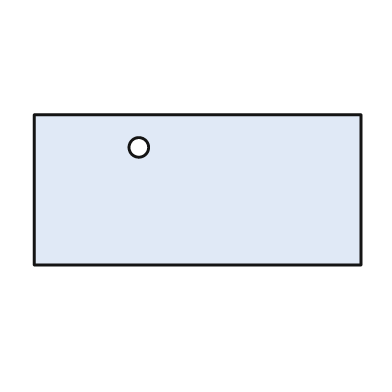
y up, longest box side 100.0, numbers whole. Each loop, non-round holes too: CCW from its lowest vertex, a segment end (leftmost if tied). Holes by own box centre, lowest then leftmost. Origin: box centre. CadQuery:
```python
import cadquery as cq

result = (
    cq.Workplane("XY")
    .moveTo(-50.0, -23.0)
    .lineTo(50.0, -23.0)
    .lineTo(50.0, 23.0)
    .lineTo(-50.0, 23.0)
    .close()
    .moveTo(-18.0, 13.0)
    .circle(3.0)
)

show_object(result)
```